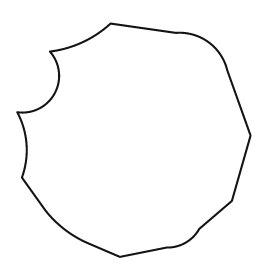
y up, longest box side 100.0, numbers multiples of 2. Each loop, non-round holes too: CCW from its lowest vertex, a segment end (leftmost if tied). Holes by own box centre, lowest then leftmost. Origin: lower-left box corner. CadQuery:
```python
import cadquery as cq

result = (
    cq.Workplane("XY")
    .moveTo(44.0, 0.0)
    .lineTo(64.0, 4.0)
    .threePointArc((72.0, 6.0), (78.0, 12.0))
    .lineTo(92.0, 24.0)
    .lineTo(100.0, 52.0)
    .lineTo(90.0, 80.0)
    .threePointArc((82.0, 92.0), (68.0, 96.0))
    .lineTo(40.0, 100.0)
    .threePointArc((28.0, 92.0), (14.0, 88.0))
    .threePointArc((16.0, 70.0), (0.0, 62.0))
    .threePointArc((4.0, 48.0), (2.0, 34.0))
    .lineTo(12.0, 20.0)
    .threePointArc((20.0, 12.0), (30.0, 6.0))
    .close()
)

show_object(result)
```